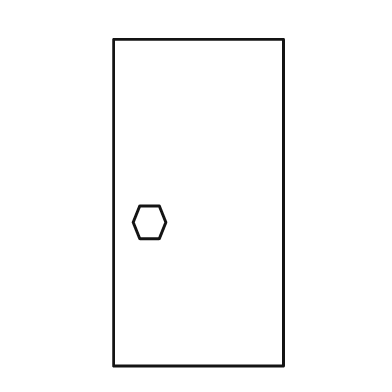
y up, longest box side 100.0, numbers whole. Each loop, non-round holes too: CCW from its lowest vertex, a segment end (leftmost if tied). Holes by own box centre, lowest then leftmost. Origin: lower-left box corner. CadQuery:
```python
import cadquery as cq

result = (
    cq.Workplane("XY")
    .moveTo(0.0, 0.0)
    .lineTo(52.0, 0.0)
    .lineTo(52.0, 100.0)
    .lineTo(0.0, 100.0)
    .close()
    .moveTo(8.0, 39.0)
    .lineTo(14.0, 39.0)
    .lineTo(16.0, 44.0)
    .lineTo(14.0, 49.0)
    .lineTo(8.0, 49.0)
    .lineTo(6.0, 44.0)
    .close()
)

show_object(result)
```